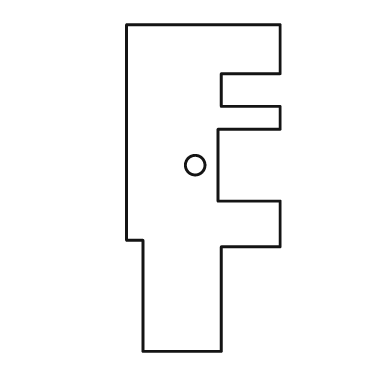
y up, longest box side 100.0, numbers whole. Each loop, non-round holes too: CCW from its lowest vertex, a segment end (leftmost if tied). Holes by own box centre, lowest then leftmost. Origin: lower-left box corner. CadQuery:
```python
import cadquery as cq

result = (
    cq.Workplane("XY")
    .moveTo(5.0, 0.0)
    .lineTo(29.0, 0.0)
    .lineTo(29.0, 32.0)
    .lineTo(47.0, 32.0)
    .lineTo(47.0, 46.0)
    .lineTo(28.0, 46.0)
    .lineTo(28.0, 68.0)
    .lineTo(47.0, 68.0)
    .lineTo(47.0, 75.0)
    .lineTo(29.0, 75.0)
    .lineTo(29.0, 85.0)
    .lineTo(47.0, 85.0)
    .lineTo(47.0, 100.0)
    .lineTo(0.0, 100.0)
    .lineTo(0.0, 34.0)
    .lineTo(5.0, 34.0)
    .close()
    .moveTo(21.0, 57.0)
    .circle(3.0)
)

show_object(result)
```